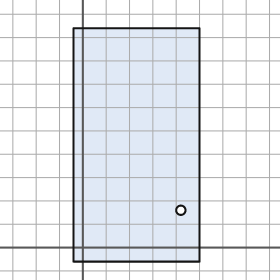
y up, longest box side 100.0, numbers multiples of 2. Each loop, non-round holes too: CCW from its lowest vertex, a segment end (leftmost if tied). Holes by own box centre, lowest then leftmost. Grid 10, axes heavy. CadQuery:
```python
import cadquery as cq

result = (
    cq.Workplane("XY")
    .moveTo(-4.0, -6.0)
    .lineTo(50.0, -6.0)
    .lineTo(50.0, 94.0)
    .lineTo(-4.0, 94.0)
    .close()
    .moveTo(42.0, 16.0)
    .circle(2.0)
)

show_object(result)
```